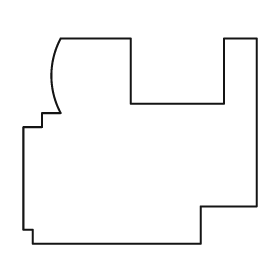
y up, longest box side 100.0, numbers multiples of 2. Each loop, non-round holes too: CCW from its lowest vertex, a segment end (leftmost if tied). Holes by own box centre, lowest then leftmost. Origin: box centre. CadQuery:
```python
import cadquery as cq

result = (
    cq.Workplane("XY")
    .moveTo(-46.0, -44.0)
    .lineTo(26.0, -44.0)
    .lineTo(26.0, -28.0)
    .lineTo(50.0, -28.0)
    .lineTo(50.0, 44.0)
    .lineTo(36.0, 44.0)
    .lineTo(36.0, 16.0)
    .lineTo(-4.0, 16.0)
    .lineTo(-4.0, 44.0)
    .lineTo(-34.0, 44.0)
    .threePointArc((-38.0, 28.0), (-34.0, 12.0))
    .lineTo(-42.0, 12.0)
    .lineTo(-42.0, 6.0)
    .lineTo(-50.0, 6.0)
    .lineTo(-50.0, -38.0)
    .lineTo(-46.0, -38.0)
    .close()
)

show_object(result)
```